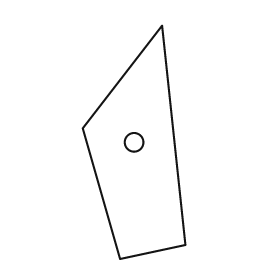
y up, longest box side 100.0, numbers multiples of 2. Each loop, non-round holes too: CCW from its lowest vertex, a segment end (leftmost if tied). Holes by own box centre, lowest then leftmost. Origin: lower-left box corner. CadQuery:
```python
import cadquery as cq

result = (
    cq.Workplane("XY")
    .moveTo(16.0, 0.0)
    .lineTo(44.0, 6.0)
    .lineTo(34.0, 100.0)
    .lineTo(0.0, 56.0)
    .close()
    .moveTo(22.0, 50.0)
    .circle(4.0)
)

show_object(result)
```